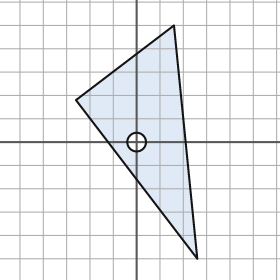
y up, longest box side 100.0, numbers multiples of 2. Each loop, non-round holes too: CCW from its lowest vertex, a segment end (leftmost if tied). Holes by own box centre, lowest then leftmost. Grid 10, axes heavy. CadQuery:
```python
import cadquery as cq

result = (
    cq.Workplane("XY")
    .moveTo(26.0, -50.0)
    .lineTo(16.0, 50.0)
    .lineTo(-26.0, 18.0)
    .close()
    .moveTo(0.0, 0.0)
    .circle(4.0)
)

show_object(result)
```